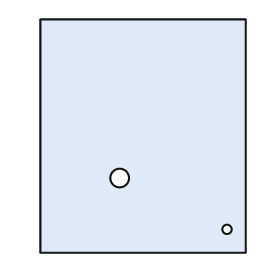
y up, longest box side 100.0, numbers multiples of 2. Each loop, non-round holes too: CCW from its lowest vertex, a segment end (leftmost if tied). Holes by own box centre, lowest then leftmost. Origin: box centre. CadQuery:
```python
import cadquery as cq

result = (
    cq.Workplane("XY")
    .moveTo(-44.0, -50.0)
    .lineTo(44.0, -50.0)
    .lineTo(44.0, 50.0)
    .lineTo(-44.0, 50.0)
    .close()
    .moveTo(36.0, -40.0)
    .circle(2.0)
    .moveTo(-10.0, -18.0)
    .circle(4.0)
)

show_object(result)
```